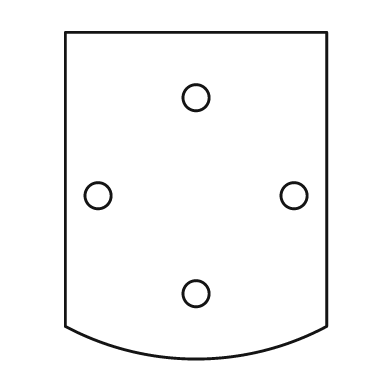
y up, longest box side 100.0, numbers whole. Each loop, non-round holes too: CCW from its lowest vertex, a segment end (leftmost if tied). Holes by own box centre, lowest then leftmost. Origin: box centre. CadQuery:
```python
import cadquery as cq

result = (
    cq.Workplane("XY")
    .moveTo(-40.0, -40.0)
    .threePointArc((0.0, -50.0), (40.0, -40.0))
    .lineTo(40.0, 50.0)
    .lineTo(-40.0, 50.0)
    .close()
    .moveTo(0.0, -30.0)
    .circle(4.0)
    .moveTo(-30.0, 0.0)
    .circle(4.0)
    .moveTo(30.0, 0.0)
    .circle(4.0)
    .moveTo(0.0, 30.0)
    .circle(4.0)
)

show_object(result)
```